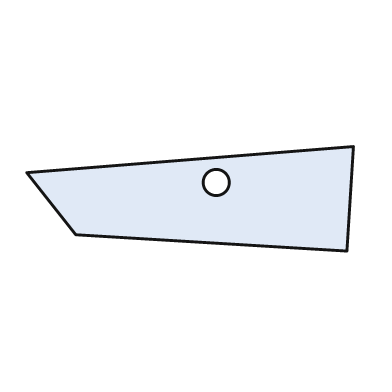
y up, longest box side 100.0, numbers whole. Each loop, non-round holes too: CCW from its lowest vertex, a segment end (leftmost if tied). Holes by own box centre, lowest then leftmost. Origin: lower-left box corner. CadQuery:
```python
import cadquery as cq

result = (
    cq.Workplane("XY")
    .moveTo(98.0, 0.0)
    .lineTo(100.0, 32.0)
    .lineTo(0.0, 24.0)
    .lineTo(15.0, 5.0)
    .close()
    .moveTo(58.0, 21.0)
    .circle(4.0)
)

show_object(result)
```